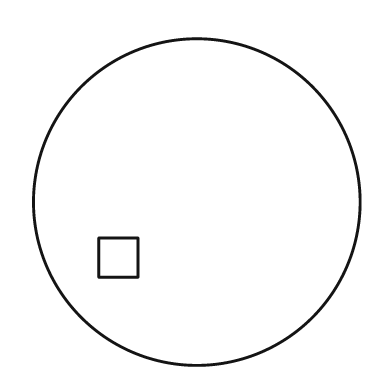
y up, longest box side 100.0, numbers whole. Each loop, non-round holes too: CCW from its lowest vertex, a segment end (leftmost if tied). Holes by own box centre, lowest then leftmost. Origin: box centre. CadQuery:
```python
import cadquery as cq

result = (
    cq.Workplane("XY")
    .moveTo(0.0, 0.0)
    .circle(50.0)
    .moveTo(-30.0, -23.0)
    .lineTo(-18.0, -23.0)
    .lineTo(-18.0, -11.0)
    .lineTo(-30.0, -11.0)
    .close()
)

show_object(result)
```